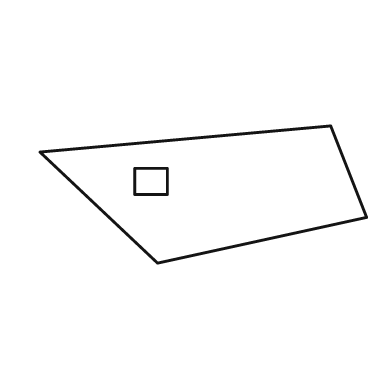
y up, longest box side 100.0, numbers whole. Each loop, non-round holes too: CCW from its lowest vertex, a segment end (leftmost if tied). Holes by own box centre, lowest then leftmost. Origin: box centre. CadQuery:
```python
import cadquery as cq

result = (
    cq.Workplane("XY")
    .moveTo(-14.0, -21.0)
    .lineTo(50.0, -7.0)
    .lineTo(39.0, 21.0)
    .lineTo(-50.0, 13.0)
    .close()
    .moveTo(-21.0, 0.0)
    .lineTo(-11.0, 0.0)
    .lineTo(-11.0, 8.0)
    .lineTo(-21.0, 8.0)
    .close()
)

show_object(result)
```